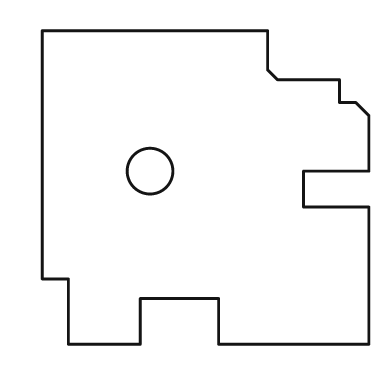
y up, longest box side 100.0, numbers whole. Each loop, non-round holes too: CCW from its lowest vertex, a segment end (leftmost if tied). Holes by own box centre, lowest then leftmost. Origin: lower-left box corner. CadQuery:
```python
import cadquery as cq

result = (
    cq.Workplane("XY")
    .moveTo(8.0, 0.0)
    .lineTo(30.0, 0.0)
    .lineTo(30.0, 14.0)
    .lineTo(54.0, 14.0)
    .lineTo(54.0, 0.0)
    .lineTo(100.0, 0.0)
    .lineTo(100.0, 42.0)
    .lineTo(80.0, 42.0)
    .lineTo(80.0, 53.0)
    .lineTo(100.0, 53.0)
    .lineTo(100.0, 70.0)
    .lineTo(96.0, 74.0)
    .lineTo(91.0, 74.0)
    .lineTo(91.0, 81.0)
    .lineTo(72.0, 81.0)
    .lineTo(69.0, 84.0)
    .lineTo(69.0, 96.0)
    .lineTo(0.0, 96.0)
    .lineTo(0.0, 20.0)
    .lineTo(8.0, 20.0)
    .close()
    .moveTo(33.0, 53.0)
    .circle(7.0)
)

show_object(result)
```